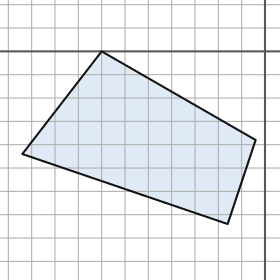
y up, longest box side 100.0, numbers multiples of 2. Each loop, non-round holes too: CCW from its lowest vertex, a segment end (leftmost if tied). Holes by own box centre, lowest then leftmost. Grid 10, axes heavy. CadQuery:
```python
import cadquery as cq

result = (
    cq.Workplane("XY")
    .moveTo(-16.0, -74.0)
    .lineTo(-4.0, -38.0)
    .lineTo(-70.0, 0.0)
    .lineTo(-104.0, -44.0)
    .close()
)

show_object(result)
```